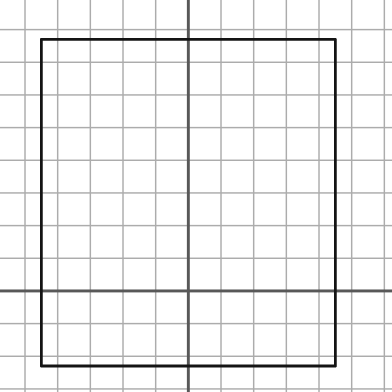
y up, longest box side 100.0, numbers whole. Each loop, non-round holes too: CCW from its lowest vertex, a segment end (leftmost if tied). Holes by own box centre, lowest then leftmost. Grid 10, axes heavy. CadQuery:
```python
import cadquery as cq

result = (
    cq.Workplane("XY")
    .moveTo(-45.0, -23.0)
    .lineTo(45.0, -23.0)
    .lineTo(45.0, 77.0)
    .lineTo(-45.0, 77.0)
    .close()
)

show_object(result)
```